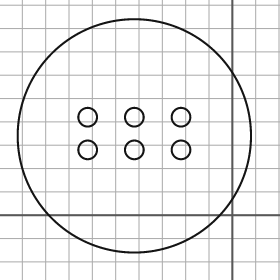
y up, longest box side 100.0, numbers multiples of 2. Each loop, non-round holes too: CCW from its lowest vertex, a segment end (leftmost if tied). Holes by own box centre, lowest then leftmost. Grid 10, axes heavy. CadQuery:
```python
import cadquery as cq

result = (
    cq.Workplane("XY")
    .moveTo(-42.0, 34.0)
    .circle(50.0)
    .moveTo(-62.0, 28.0)
    .circle(4.0)
    .moveTo(-42.0, 28.0)
    .circle(4.0)
    .moveTo(-22.0, 28.0)
    .circle(4.0)
    .moveTo(-62.0, 42.0)
    .circle(4.0)
    .moveTo(-42.0, 42.0)
    .circle(4.0)
    .moveTo(-22.0, 42.0)
    .circle(4.0)
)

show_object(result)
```